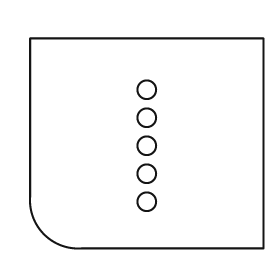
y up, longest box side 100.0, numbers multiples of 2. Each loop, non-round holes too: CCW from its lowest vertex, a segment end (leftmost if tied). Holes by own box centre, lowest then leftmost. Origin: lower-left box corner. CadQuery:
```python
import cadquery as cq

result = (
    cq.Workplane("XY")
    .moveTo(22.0, 0.0)
    .lineTo(100.0, 0.0)
    .lineTo(100.0, 90.0)
    .lineTo(0.0, 90.0)
    .lineTo(0.0, 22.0)
    .threePointArc((6.0, 6.0), (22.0, 0.0))
    .close()
    .moveTo(50.0, 20.0)
    .circle(4.0)
    .moveTo(50.0, 32.0)
    .circle(4.0)
    .moveTo(50.0, 44.0)
    .circle(4.0)
    .moveTo(50.0, 56.0)
    .circle(4.0)
    .moveTo(50.0, 68.0)
    .circle(4.0)
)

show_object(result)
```